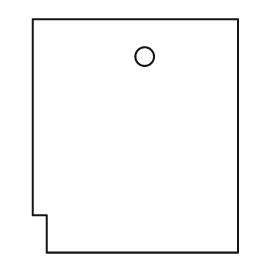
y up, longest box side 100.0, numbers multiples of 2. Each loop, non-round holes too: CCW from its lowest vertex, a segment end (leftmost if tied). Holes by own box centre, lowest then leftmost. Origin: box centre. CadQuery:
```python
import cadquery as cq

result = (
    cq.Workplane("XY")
    .moveTo(-38.0, -50.0)
    .lineTo(44.0, -50.0)
    .lineTo(44.0, 50.0)
    .lineTo(-44.0, 50.0)
    .lineTo(-44.0, -34.0)
    .lineTo(-38.0, -34.0)
    .close()
    .moveTo(4.0, 34.0)
    .circle(4.0)
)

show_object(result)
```